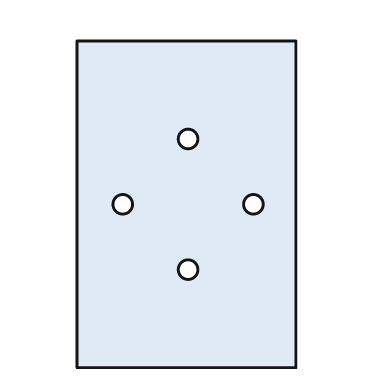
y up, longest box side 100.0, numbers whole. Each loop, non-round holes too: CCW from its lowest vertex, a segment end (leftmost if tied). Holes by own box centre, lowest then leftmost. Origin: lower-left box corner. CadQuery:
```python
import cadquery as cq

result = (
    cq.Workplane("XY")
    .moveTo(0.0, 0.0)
    .lineTo(67.0, 0.0)
    .lineTo(67.0, 100.0)
    .lineTo(0.0, 100.0)
    .close()
    .moveTo(34.0, 30.0)
    .circle(3.0)
    .moveTo(14.0, 50.0)
    .circle(3.0)
    .moveTo(54.0, 50.0)
    .circle(3.0)
    .moveTo(34.0, 70.0)
    .circle(3.0)
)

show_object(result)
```